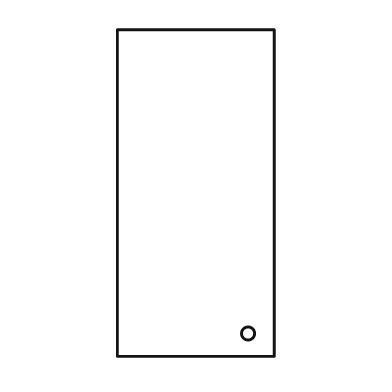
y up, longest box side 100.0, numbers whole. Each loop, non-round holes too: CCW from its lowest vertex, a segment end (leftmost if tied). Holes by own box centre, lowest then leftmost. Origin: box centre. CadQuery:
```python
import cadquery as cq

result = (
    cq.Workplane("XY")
    .moveTo(-24.0, -50.0)
    .lineTo(24.0, -50.0)
    .lineTo(24.0, 50.0)
    .lineTo(-24.0, 50.0)
    .close()
    .moveTo(16.0, -43.0)
    .circle(2.0)
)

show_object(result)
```